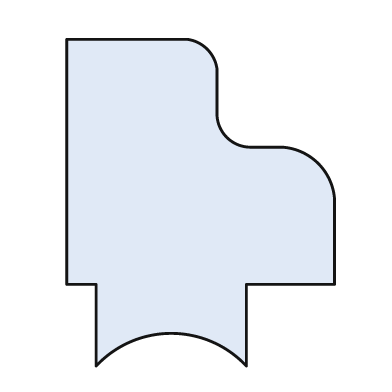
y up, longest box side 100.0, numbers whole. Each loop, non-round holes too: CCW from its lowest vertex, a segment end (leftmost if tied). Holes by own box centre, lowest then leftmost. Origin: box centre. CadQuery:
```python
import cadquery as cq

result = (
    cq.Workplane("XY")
    .moveTo(-32.0, -50.0)
    .threePointArc((-9.0, -40.0), (14.0, -50.0))
    .lineTo(14.0, -25.0)
    .lineTo(41.0, -25.0)
    .lineTo(41.0, 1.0)
    .threePointArc((36.0, 12.0), (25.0, 17.0))
    .lineTo(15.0, 17.0)
    .threePointArc((8.0, 20.0), (5.0, 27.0))
    .lineTo(5.0, 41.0)
    .threePointArc((2.0, 47.0), (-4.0, 50.0))
    .lineTo(-41.0, 50.0)
    .lineTo(-41.0, -25.0)
    .lineTo(-32.0, -25.0)
    .close()
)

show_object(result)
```